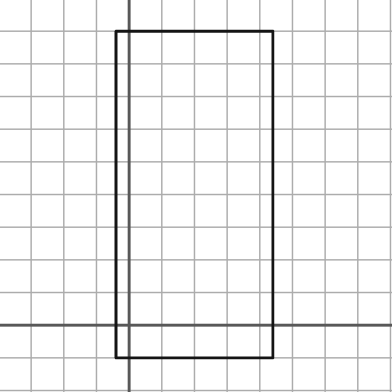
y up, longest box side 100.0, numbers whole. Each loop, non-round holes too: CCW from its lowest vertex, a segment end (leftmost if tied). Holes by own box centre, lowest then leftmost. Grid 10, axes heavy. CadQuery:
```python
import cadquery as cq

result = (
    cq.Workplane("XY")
    .moveTo(-4.0, -10.0)
    .lineTo(44.0, -10.0)
    .lineTo(44.0, 90.0)
    .lineTo(-4.0, 90.0)
    .close()
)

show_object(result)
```